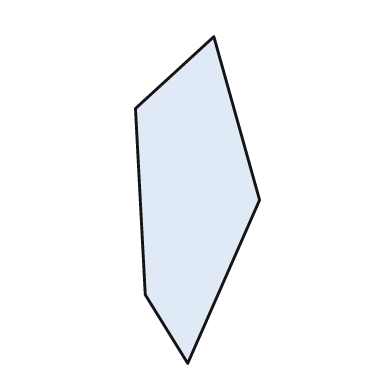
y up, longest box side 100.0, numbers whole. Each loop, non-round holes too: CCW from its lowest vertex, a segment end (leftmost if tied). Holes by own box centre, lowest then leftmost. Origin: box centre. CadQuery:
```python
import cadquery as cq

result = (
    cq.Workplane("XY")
    .moveTo(-3.0, -50.0)
    .lineTo(19.0, 0.0)
    .lineTo(5.0, 50.0)
    .lineTo(-19.0, 28.0)
    .lineTo(-16.0, -29.0)
    .close()
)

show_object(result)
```